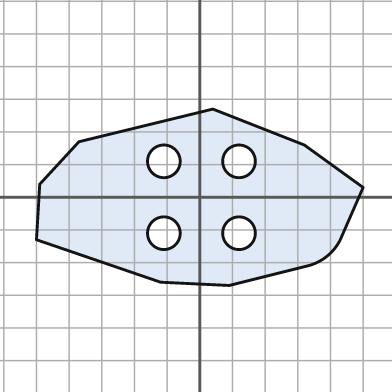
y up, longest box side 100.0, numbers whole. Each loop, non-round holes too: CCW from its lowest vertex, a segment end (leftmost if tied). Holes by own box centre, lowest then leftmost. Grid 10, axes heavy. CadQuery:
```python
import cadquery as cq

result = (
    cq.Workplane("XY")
    .moveTo(9.0, -27.0)
    .lineTo(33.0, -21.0)
    .threePointArc((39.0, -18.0), (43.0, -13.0))
    .lineTo(50.0, 3.0)
    .lineTo(32.0, 16.0)
    .lineTo(4.0, 27.0)
    .lineTo(-37.0, 17.0)
    .lineTo(-49.0, 4.0)
    .lineTo(-50.0, -13.0)
    .lineTo(-12.0, -26.0)
    .close()
    .moveTo(-11.0, -11.0)
    .circle(5.0)
    .moveTo(12.0, -11.0)
    .circle(5.0)
    .moveTo(-11.0, 11.0)
    .circle(5.0)
    .moveTo(12.0, 11.0)
    .circle(5.0)
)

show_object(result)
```